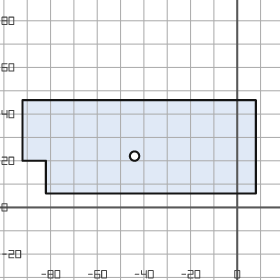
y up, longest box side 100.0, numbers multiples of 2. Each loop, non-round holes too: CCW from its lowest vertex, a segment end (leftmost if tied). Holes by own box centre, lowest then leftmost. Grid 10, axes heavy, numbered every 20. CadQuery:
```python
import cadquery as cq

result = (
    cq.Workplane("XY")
    .moveTo(-82.0, 6.0)
    .lineTo(8.0, 6.0)
    .lineTo(8.0, 46.0)
    .lineTo(-92.0, 46.0)
    .lineTo(-92.0, 20.0)
    .lineTo(-82.0, 20.0)
    .close()
    .moveTo(-44.0, 22.0)
    .circle(2.0)
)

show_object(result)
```